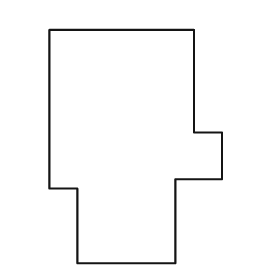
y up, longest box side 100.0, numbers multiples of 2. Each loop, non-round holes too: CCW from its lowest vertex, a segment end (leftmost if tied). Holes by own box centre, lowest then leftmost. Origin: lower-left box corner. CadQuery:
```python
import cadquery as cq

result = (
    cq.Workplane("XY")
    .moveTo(12.0, 0.0)
    .lineTo(54.0, 0.0)
    .lineTo(54.0, 36.0)
    .lineTo(74.0, 36.0)
    .lineTo(74.0, 56.0)
    .lineTo(62.0, 56.0)
    .lineTo(62.0, 100.0)
    .lineTo(0.0, 100.0)
    .lineTo(0.0, 32.0)
    .lineTo(12.0, 32.0)
    .close()
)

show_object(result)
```